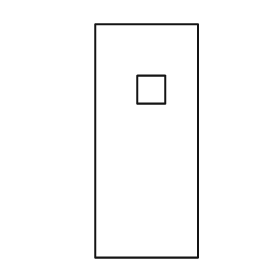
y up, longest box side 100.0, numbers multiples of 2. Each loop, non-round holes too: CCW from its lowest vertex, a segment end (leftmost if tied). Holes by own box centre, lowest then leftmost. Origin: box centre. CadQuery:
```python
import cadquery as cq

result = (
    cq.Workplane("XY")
    .moveTo(-22.0, -50.0)
    .lineTo(22.0, -50.0)
    .lineTo(22.0, 50.0)
    .lineTo(-22.0, 50.0)
    .close()
    .moveTo(-4.0, 16.0)
    .lineTo(8.0, 16.0)
    .lineTo(8.0, 28.0)
    .lineTo(-4.0, 28.0)
    .close()
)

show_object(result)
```